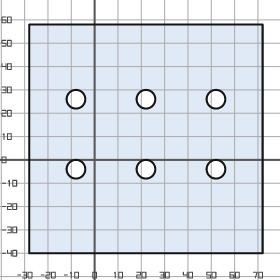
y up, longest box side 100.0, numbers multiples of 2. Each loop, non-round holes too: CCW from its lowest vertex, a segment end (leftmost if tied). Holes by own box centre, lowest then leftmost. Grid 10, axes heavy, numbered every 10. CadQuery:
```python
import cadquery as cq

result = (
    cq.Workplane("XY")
    .moveTo(-28.0, -40.0)
    .lineTo(72.0, -40.0)
    .lineTo(72.0, 58.0)
    .lineTo(-28.0, 58.0)
    .close()
    .moveTo(-8.0, -4.0)
    .circle(4.0)
    .moveTo(22.0, -4.0)
    .circle(4.0)
    .moveTo(52.0, -4.0)
    .circle(4.0)
    .moveTo(-8.0, 26.0)
    .circle(4.0)
    .moveTo(22.0, 26.0)
    .circle(4.0)
    .moveTo(52.0, 26.0)
    .circle(4.0)
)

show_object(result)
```